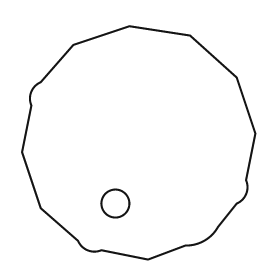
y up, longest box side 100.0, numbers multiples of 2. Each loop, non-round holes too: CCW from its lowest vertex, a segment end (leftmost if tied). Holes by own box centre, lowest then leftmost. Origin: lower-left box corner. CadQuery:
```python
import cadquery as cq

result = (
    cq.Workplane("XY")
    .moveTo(54.0, 0.0)
    .lineTo(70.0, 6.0)
    .threePointArc((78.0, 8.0), (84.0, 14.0))
    .lineTo(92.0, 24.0)
    .threePointArc((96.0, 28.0), (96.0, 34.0))
    .lineTo(100.0, 54.0)
    .lineTo(92.0, 78.0)
    .lineTo(72.0, 96.0)
    .lineTo(46.0, 100.0)
    .lineTo(22.0, 92.0)
    .lineTo(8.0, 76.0)
    .threePointArc((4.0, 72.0), (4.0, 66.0))
    .lineTo(0.0, 46.0)
    .lineTo(8.0, 22.0)
    .lineTo(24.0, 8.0)
    .threePointArc((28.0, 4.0), (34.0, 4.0))
    .close()
    .moveTo(40.0, 24.0)
    .circle(6.0)
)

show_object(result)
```